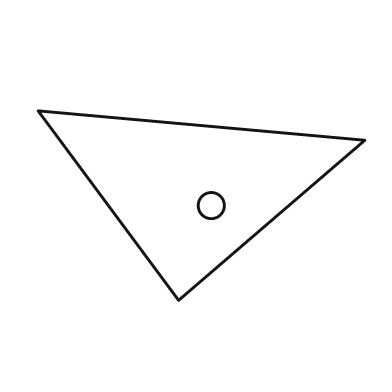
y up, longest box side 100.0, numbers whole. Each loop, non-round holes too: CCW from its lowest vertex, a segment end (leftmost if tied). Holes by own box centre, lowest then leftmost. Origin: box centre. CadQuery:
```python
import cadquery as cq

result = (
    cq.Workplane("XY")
    .moveTo(-7.0, -29.0)
    .lineTo(50.0, 20.0)
    .lineTo(-50.0, 29.0)
    .close()
    .moveTo(3.0, 0.0)
    .circle(4.0)
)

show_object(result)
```